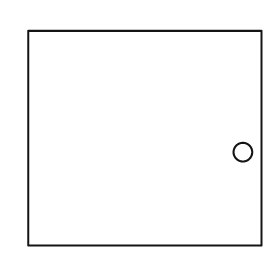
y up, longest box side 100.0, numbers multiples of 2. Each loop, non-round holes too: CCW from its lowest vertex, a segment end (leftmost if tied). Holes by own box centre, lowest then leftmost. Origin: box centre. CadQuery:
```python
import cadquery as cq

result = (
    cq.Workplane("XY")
    .moveTo(-50.0, -46.0)
    .lineTo(50.0, -46.0)
    .lineTo(50.0, 46.0)
    .lineTo(-50.0, 46.0)
    .close()
    .moveTo(42.0, -6.0)
    .circle(4.0)
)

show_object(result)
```